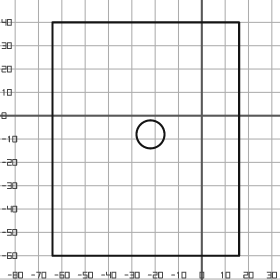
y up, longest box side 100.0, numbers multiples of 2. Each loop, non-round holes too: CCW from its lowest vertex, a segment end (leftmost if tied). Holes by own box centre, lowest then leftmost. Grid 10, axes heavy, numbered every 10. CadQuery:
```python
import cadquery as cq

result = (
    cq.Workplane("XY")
    .moveTo(-64.0, -60.0)
    .lineTo(16.0, -60.0)
    .lineTo(16.0, 40.0)
    .lineTo(-64.0, 40.0)
    .close()
    .moveTo(-22.0, -8.0)
    .circle(6.0)
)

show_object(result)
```